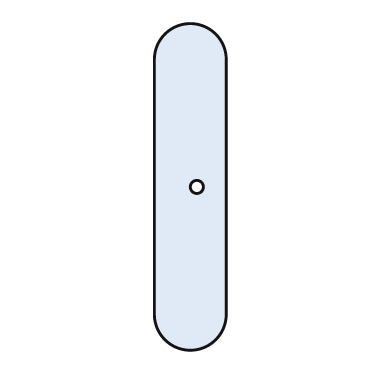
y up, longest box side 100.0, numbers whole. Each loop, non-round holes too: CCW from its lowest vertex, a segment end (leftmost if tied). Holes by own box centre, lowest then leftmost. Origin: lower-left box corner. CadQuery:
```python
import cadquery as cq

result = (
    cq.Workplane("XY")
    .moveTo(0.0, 11.0)
    .threePointArc((11.0, 0.0), (22.0, 11.0))
    .lineTo(22.0, 89.0)
    .threePointArc((11.0, 100.0), (0.0, 89.0))
    .close()
    .moveTo(13.0, 50.0)
    .circle(2.0)
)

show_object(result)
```